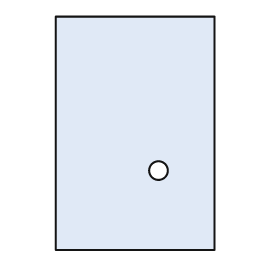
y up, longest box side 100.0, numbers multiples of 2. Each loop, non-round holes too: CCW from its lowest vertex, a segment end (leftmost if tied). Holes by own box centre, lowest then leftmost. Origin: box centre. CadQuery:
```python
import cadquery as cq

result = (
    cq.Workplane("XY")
    .moveTo(-34.0, -50.0)
    .lineTo(34.0, -50.0)
    .lineTo(34.0, 50.0)
    .lineTo(-34.0, 50.0)
    .close()
    .moveTo(10.0, -16.0)
    .circle(4.0)
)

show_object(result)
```